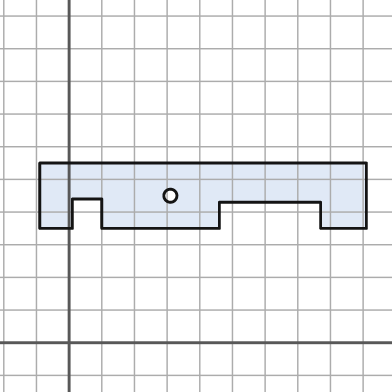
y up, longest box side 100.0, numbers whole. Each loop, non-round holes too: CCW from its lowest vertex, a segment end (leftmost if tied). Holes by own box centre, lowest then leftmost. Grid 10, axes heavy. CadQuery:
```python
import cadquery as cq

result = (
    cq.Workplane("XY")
    .moveTo(-9.0, 35.0)
    .lineTo(1.0, 35.0)
    .lineTo(1.0, 44.0)
    .lineTo(10.0, 44.0)
    .lineTo(10.0, 35.0)
    .lineTo(46.0, 35.0)
    .lineTo(46.0, 43.0)
    .lineTo(77.0, 43.0)
    .lineTo(77.0, 35.0)
    .lineTo(91.0, 35.0)
    .lineTo(91.0, 55.0)
    .lineTo(-9.0, 55.0)
    .close()
    .moveTo(31.0, 45.0)
    .circle(2.0)
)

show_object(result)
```